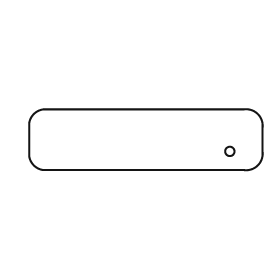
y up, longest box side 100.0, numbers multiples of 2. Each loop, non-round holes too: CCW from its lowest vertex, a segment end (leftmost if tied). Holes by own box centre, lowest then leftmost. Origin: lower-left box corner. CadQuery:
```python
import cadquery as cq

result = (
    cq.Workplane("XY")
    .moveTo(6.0, 0.0)
    .lineTo(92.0, 0.0)
    .threePointArc((98.0, 2.0), (100.0, 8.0))
    .lineTo(100.0, 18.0)
    .threePointArc((98.0, 24.0), (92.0, 26.0))
    .lineTo(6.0, 26.0)
    .threePointArc((2.0, 24.0), (0.0, 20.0))
    .lineTo(0.0, 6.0)
    .threePointArc((2.0, 2.0), (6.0, 0.0))
    .close()
    .moveTo(86.0, 8.0)
    .circle(2.0)
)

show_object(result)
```